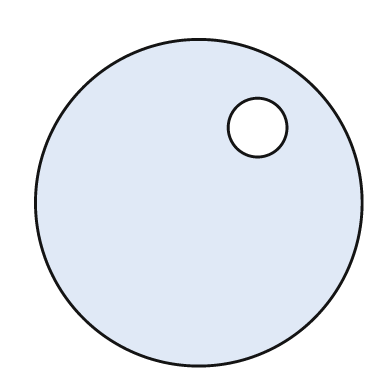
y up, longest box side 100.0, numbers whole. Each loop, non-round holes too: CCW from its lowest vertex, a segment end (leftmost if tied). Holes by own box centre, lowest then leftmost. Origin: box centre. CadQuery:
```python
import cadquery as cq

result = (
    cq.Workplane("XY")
    .moveTo(0.0, 0.0)
    .circle(50.0)
    .moveTo(18.0, 23.0)
    .circle(9.0)
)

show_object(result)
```